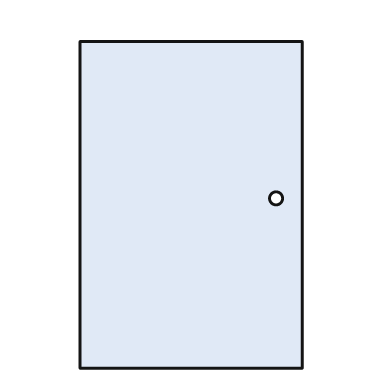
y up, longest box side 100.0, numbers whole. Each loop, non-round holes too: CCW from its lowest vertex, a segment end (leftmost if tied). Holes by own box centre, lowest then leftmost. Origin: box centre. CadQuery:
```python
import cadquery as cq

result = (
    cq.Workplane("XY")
    .moveTo(-34.0, -50.0)
    .lineTo(34.0, -50.0)
    .lineTo(34.0, 50.0)
    .lineTo(-34.0, 50.0)
    .close()
    .moveTo(26.0, 2.0)
    .circle(2.0)
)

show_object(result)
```